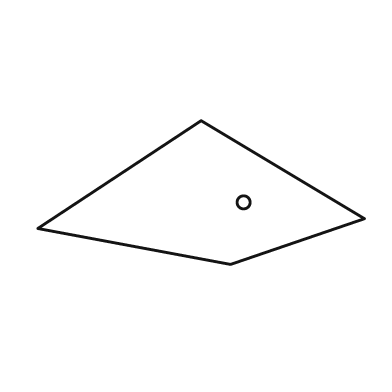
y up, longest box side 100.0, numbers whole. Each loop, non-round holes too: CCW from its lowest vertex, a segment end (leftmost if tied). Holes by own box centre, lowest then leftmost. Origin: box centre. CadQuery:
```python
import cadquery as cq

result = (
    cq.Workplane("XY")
    .moveTo(9.0, -22.0)
    .lineTo(50.0, -8.0)
    .lineTo(0.0, 22.0)
    .lineTo(-50.0, -11.0)
    .close()
    .moveTo(13.0, -3.0)
    .circle(2.0)
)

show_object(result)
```